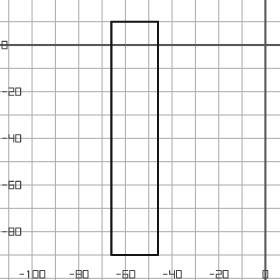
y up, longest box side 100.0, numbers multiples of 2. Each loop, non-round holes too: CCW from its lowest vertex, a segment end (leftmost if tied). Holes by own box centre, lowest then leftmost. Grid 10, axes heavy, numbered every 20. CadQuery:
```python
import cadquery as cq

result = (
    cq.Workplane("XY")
    .moveTo(-66.0, -90.0)
    .lineTo(-46.0, -90.0)
    .lineTo(-46.0, 10.0)
    .lineTo(-66.0, 10.0)
    .close()
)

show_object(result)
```